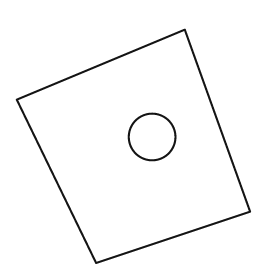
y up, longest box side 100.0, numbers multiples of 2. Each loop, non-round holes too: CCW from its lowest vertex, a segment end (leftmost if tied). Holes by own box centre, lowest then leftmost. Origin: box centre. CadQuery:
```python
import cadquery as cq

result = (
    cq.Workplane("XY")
    .moveTo(-16.0, -50.0)
    .lineTo(50.0, -28.0)
    .lineTo(22.0, 50.0)
    .lineTo(-50.0, 20.0)
    .close()
    .moveTo(8.0, 4.0)
    .circle(10.0)
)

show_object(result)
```